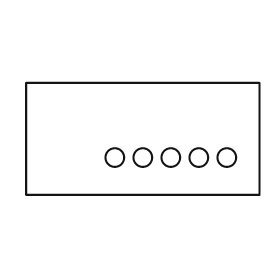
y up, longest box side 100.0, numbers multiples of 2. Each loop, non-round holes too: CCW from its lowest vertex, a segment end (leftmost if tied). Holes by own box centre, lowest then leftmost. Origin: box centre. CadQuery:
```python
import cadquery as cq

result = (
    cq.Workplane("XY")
    .moveTo(-50.0, -24.0)
    .lineTo(50.0, -24.0)
    .lineTo(50.0, 24.0)
    .lineTo(-50.0, 24.0)
    .close()
    .moveTo(-12.0, -8.0)
    .circle(4.0)
    .moveTo(0.0, -8.0)
    .circle(4.0)
    .moveTo(12.0, -8.0)
    .circle(4.0)
    .moveTo(24.0, -8.0)
    .circle(4.0)
    .moveTo(36.0, -8.0)
    .circle(4.0)
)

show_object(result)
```